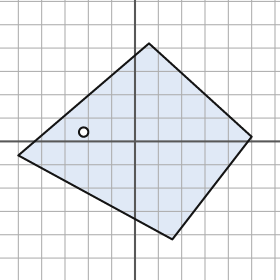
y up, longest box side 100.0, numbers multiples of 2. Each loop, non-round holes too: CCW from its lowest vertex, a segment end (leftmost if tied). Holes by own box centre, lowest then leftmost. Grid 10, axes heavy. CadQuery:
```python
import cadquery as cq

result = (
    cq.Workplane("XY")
    .moveTo(16.0, -42.0)
    .lineTo(50.0, 2.0)
    .lineTo(6.0, 42.0)
    .lineTo(-50.0, -6.0)
    .close()
    .moveTo(-22.0, 4.0)
    .circle(2.0)
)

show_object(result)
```